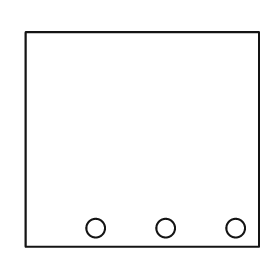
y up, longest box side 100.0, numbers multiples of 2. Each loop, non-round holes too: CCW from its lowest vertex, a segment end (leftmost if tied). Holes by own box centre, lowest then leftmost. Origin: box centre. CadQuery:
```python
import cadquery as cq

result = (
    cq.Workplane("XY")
    .moveTo(-50.0, -46.0)
    .lineTo(50.0, -46.0)
    .lineTo(50.0, 46.0)
    .lineTo(-50.0, 46.0)
    .close()
    .moveTo(-20.0, -38.0)
    .circle(4.0)
    .moveTo(10.0, -38.0)
    .circle(4.0)
    .moveTo(40.0, -38.0)
    .circle(4.0)
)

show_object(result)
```